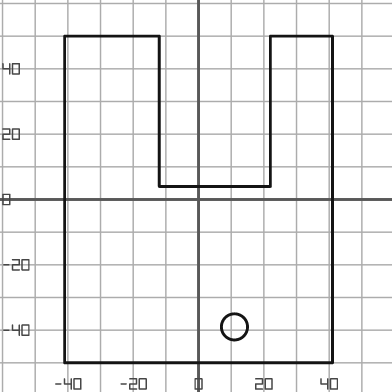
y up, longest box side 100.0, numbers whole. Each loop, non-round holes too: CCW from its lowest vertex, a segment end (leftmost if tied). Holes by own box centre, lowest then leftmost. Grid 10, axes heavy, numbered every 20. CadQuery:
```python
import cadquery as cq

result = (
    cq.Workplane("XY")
    .moveTo(-41.0, -50.0)
    .lineTo(41.0, -50.0)
    .lineTo(41.0, 50.0)
    .lineTo(22.0, 50.0)
    .lineTo(22.0, 4.0)
    .lineTo(-12.0, 4.0)
    .lineTo(-12.0, 50.0)
    .lineTo(-41.0, 50.0)
    .close()
    .moveTo(11.0, -39.0)
    .circle(4.0)
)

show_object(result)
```